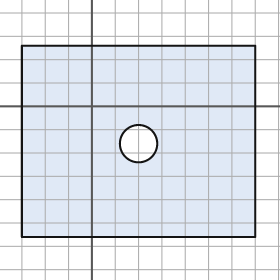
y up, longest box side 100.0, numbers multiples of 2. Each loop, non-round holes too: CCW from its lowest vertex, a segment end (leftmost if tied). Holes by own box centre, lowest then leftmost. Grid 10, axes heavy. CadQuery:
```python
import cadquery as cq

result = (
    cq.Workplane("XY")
    .moveTo(-30.0, -56.0)
    .lineTo(70.0, -56.0)
    .lineTo(70.0, 26.0)
    .lineTo(-30.0, 26.0)
    .close()
    .moveTo(20.0, -16.0)
    .circle(8.0)
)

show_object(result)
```